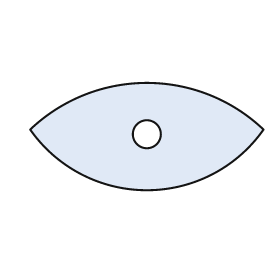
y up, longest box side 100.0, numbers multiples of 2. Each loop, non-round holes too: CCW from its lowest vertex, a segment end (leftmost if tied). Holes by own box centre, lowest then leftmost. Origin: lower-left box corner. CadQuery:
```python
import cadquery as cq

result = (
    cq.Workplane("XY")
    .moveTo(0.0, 26.0)
    .threePointArc((50.0, 0.0), (100.0, 26.0))
    .threePointArc((50.0, 46.0), (0.0, 26.0))
    .close()
    .moveTo(50.0, 24.0)
    .circle(6.0)
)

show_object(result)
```